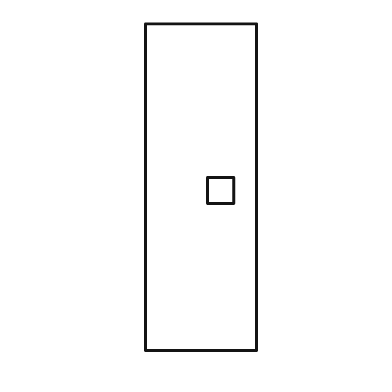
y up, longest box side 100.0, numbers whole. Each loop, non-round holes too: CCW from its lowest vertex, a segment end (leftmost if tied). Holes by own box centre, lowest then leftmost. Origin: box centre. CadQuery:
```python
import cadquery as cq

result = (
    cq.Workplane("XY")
    .moveTo(-17.0, -50.0)
    .lineTo(17.0, -50.0)
    .lineTo(17.0, 50.0)
    .lineTo(-17.0, 50.0)
    .close()
    .moveTo(2.0, -5.0)
    .lineTo(10.0, -5.0)
    .lineTo(10.0, 3.0)
    .lineTo(2.0, 3.0)
    .close()
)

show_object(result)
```